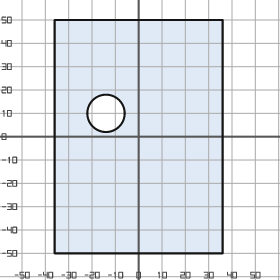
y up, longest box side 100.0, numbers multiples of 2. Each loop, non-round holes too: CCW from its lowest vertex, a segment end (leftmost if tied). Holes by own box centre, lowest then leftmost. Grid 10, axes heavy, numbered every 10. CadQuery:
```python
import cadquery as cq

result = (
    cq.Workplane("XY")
    .moveTo(-36.0, -50.0)
    .lineTo(36.0, -50.0)
    .lineTo(36.0, 50.0)
    .lineTo(-36.0, 50.0)
    .close()
    .moveTo(-14.0, 10.0)
    .circle(8.0)
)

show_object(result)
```